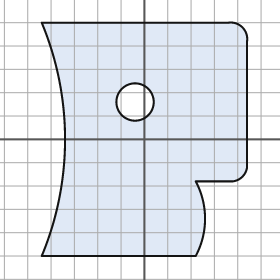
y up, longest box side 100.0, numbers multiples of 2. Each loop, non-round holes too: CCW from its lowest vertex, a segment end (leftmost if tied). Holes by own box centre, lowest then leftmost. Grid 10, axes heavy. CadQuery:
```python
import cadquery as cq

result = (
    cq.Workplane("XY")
    .moveTo(-44.0, -50.0)
    .lineTo(22.0, -50.0)
    .threePointArc((26.0, -34.0), (22.0, -18.0))
    .lineTo(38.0, -18.0)
    .threePointArc((42.0, -16.0), (44.0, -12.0))
    .lineTo(44.0, 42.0)
    .threePointArc((42.0, 48.0), (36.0, 50.0))
    .lineTo(-44.0, 50.0)
    .threePointArc((-34.0, 0.0), (-44.0, -50.0))
    .close()
    .moveTo(-4.0, 16.0)
    .circle(8.0)
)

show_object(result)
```